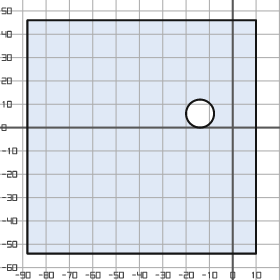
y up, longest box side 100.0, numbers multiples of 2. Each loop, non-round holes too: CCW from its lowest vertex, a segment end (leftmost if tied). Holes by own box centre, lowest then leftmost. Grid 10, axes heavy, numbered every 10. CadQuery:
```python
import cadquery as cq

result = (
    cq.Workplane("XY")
    .moveTo(-88.0, -54.0)
    .lineTo(10.0, -54.0)
    .lineTo(10.0, 46.0)
    .lineTo(-88.0, 46.0)
    .close()
    .moveTo(-14.0, 6.0)
    .circle(6.0)
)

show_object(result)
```